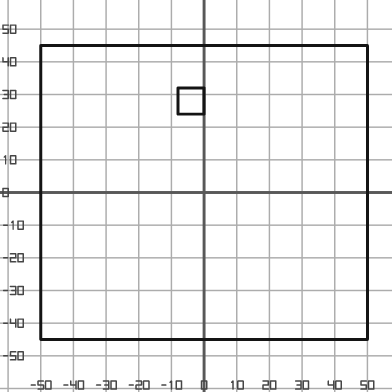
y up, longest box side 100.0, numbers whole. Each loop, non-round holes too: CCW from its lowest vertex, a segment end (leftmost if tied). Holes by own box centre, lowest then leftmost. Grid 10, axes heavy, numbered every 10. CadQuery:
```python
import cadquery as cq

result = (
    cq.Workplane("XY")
    .moveTo(-50.0, -45.0)
    .lineTo(50.0, -45.0)
    .lineTo(50.0, 45.0)
    .lineTo(-50.0, 45.0)
    .close()
    .moveTo(-8.0, 24.0)
    .lineTo(0.0, 24.0)
    .lineTo(0.0, 32.0)
    .lineTo(-8.0, 32.0)
    .close()
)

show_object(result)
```